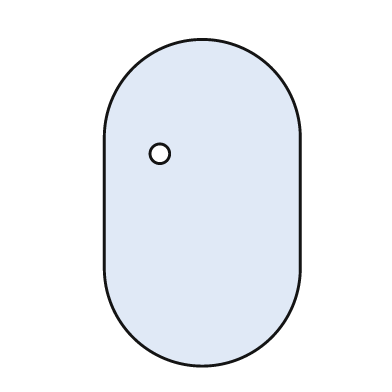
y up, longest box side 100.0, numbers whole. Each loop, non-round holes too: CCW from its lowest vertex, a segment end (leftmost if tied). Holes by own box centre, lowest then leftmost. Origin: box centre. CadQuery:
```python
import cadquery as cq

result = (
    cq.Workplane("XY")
    .moveTo(-30.0, -20.0)
    .threePointArc((0.0, -50.0), (30.0, -20.0))
    .lineTo(30.0, 20.0)
    .threePointArc((0.0, 50.0), (-30.0, 20.0))
    .close()
    .moveTo(-13.0, 15.0)
    .circle(3.0)
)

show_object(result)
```